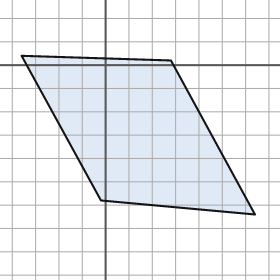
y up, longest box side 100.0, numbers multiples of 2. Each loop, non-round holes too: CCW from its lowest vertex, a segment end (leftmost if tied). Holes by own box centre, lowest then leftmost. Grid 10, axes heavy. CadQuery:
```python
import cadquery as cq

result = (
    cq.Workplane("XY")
    .moveTo(64.0, -64.0)
    .lineTo(28.0, 2.0)
    .lineTo(-36.0, 4.0)
    .lineTo(-2.0, -58.0)
    .close()
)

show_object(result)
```